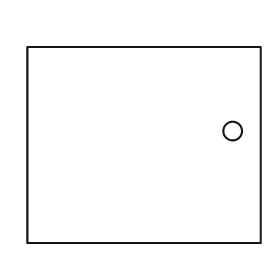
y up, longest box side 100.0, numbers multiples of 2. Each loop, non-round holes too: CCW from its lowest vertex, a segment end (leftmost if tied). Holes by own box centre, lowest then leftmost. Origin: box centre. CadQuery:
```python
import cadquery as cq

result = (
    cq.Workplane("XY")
    .moveTo(-50.0, -42.0)
    .lineTo(50.0, -42.0)
    .lineTo(50.0, 42.0)
    .lineTo(-50.0, 42.0)
    .close()
    .moveTo(38.0, 6.0)
    .circle(4.0)
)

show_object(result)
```